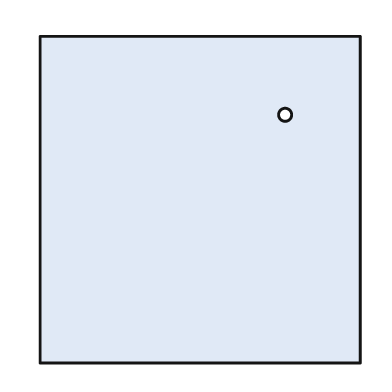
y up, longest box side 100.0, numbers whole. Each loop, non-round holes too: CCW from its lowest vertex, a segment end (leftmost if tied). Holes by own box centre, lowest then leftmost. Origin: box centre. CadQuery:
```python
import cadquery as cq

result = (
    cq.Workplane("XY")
    .moveTo(-49.0, -50.0)
    .lineTo(49.0, -50.0)
    .lineTo(49.0, 50.0)
    .lineTo(-49.0, 50.0)
    .close()
    .moveTo(26.0, 26.0)
    .circle(2.0)
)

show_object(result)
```